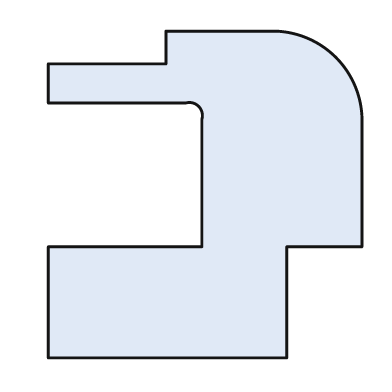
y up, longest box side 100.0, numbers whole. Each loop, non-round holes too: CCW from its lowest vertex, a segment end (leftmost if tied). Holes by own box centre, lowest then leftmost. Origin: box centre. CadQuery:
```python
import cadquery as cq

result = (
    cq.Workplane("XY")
    .moveTo(-48.0, -50.0)
    .lineTo(25.0, -50.0)
    .lineTo(25.0, -16.0)
    .lineTo(48.0, -16.0)
    .lineTo(48.0, 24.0)
    .threePointArc((40.0, 42.0), (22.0, 50.0))
    .lineTo(-12.0, 50.0)
    .lineTo(-12.0, 40.0)
    .lineTo(-48.0, 40.0)
    .lineTo(-48.0, 28.0)
    .lineTo(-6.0, 28.0)
    .threePointArc((-2.0, 27.0), (-1.0, 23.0))
    .lineTo(-1.0, -16.0)
    .lineTo(-48.0, -16.0)
    .close()
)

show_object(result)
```